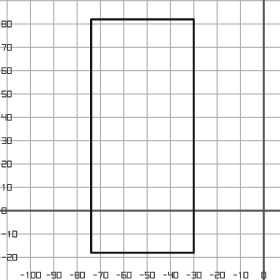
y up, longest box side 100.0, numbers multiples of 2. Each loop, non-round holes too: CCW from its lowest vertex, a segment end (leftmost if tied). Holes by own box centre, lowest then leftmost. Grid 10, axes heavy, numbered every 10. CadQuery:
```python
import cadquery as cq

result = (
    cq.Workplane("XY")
    .moveTo(-74.0, -18.0)
    .lineTo(-30.0, -18.0)
    .lineTo(-30.0, 82.0)
    .lineTo(-74.0, 82.0)
    .close()
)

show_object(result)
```